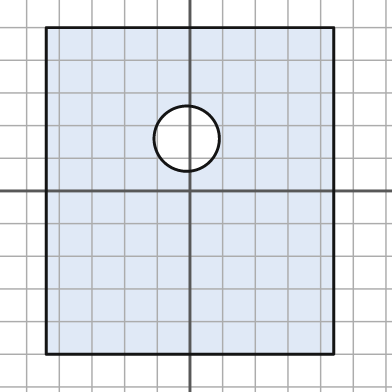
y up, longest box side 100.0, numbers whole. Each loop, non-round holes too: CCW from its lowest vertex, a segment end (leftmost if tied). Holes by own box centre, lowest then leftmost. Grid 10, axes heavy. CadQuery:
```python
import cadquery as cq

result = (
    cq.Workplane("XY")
    .moveTo(-44.0, -50.0)
    .lineTo(44.0, -50.0)
    .lineTo(44.0, 50.0)
    .lineTo(-44.0, 50.0)
    .close()
    .moveTo(-1.0, 16.0)
    .circle(10.0)
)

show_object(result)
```